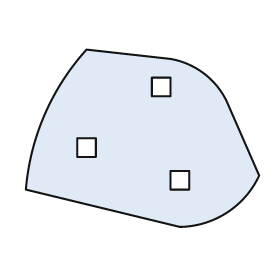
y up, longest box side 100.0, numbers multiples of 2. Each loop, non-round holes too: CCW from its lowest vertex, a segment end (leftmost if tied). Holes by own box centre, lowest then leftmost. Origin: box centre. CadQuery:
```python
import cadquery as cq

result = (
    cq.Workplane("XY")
    .moveTo(16.0, -38.0)
    .threePointArc((36.0, -32.0), (50.0, -16.0))
    .lineTo(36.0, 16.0)
    .threePointArc((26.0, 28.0), (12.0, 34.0))
    .lineTo(-24.0, 38.0)
    .threePointArc((-42.0, 10.0), (-50.0, -22.0))
    .close()
    .moveTo(12.0, -22.0)
    .lineTo(20.0, -22.0)
    .lineTo(20.0, -14.0)
    .lineTo(12.0, -14.0)
    .close()
    .moveTo(-28.0, -8.0)
    .lineTo(-20.0, -8.0)
    .lineTo(-20.0, 0.0)
    .lineTo(-28.0, 0.0)
    .close()
    .moveTo(4.0, 18.0)
    .lineTo(12.0, 18.0)
    .lineTo(12.0, 26.0)
    .lineTo(4.0, 26.0)
    .close()
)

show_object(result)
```